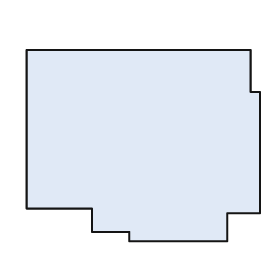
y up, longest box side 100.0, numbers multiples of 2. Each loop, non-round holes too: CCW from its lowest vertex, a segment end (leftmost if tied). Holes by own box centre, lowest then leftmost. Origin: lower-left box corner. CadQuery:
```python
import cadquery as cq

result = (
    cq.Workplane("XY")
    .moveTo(44.0, 0.0)
    .lineTo(86.0, 0.0)
    .lineTo(86.0, 12.0)
    .lineTo(100.0, 12.0)
    .lineTo(100.0, 64.0)
    .lineTo(96.0, 64.0)
    .lineTo(96.0, 82.0)
    .lineTo(0.0, 82.0)
    .lineTo(0.0, 14.0)
    .lineTo(28.0, 14.0)
    .lineTo(28.0, 4.0)
    .lineTo(44.0, 4.0)
    .close()
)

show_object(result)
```